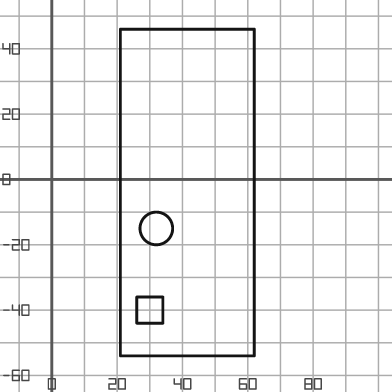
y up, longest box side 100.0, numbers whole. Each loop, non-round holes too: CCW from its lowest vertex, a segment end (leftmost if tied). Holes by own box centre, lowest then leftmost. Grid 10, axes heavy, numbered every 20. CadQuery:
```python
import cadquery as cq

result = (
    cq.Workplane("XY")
    .moveTo(21.0, -54.0)
    .lineTo(62.0, -54.0)
    .lineTo(62.0, 46.0)
    .lineTo(21.0, 46.0)
    .close()
    .moveTo(26.0, -44.0)
    .lineTo(34.0, -44.0)
    .lineTo(34.0, -36.0)
    .lineTo(26.0, -36.0)
    .close()
    .moveTo(32.0, -15.0)
    .circle(5.0)
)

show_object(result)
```